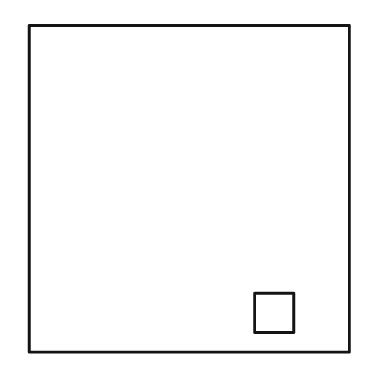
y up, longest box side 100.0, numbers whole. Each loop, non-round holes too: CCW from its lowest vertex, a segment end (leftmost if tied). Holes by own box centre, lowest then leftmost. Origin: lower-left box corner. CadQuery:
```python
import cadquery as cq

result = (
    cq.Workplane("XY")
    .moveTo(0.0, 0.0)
    .lineTo(98.0, 0.0)
    .lineTo(98.0, 100.0)
    .lineTo(0.0, 100.0)
    .close()
    .moveTo(69.0, 6.0)
    .lineTo(81.0, 6.0)
    .lineTo(81.0, 18.0)
    .lineTo(69.0, 18.0)
    .close()
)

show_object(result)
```